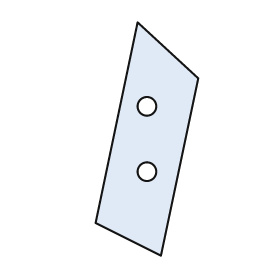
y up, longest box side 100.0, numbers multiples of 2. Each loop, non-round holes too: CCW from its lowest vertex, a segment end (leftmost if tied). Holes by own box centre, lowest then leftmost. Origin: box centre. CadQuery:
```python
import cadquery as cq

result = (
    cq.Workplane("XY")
    .moveTo(6.0, -50.0)
    .lineTo(22.0, 26.0)
    .lineTo(-4.0, 50.0)
    .lineTo(-22.0, -36.0)
    .close()
    .moveTo(0.0, -14.0)
    .circle(4.0)
    .moveTo(0.0, 14.0)
    .circle(4.0)
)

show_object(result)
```